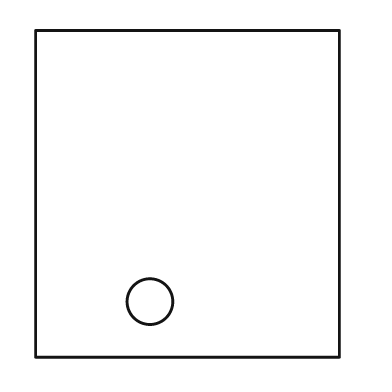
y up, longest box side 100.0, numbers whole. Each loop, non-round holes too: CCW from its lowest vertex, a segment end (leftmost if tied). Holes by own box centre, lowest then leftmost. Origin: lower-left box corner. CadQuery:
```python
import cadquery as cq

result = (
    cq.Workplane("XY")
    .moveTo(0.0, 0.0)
    .lineTo(93.0, 0.0)
    .lineTo(93.0, 100.0)
    .lineTo(0.0, 100.0)
    .close()
    .moveTo(35.0, 17.0)
    .circle(7.0)
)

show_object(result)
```